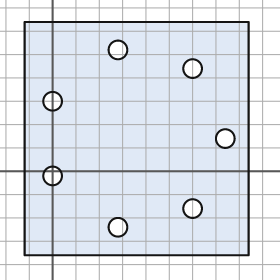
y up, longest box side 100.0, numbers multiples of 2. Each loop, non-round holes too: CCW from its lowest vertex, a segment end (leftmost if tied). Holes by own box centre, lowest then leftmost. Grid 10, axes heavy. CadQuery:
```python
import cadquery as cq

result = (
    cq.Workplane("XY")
    .moveTo(-12.0, -36.0)
    .lineTo(84.0, -36.0)
    .lineTo(84.0, 64.0)
    .lineTo(-12.0, 64.0)
    .close()
    .moveTo(28.0, -24.0)
    .circle(4.0)
    .moveTo(60.0, -16.0)
    .circle(4.0)
    .moveTo(0.0, -2.0)
    .circle(4.0)
    .moveTo(74.0, 14.0)
    .circle(4.0)
    .moveTo(0.0, 30.0)
    .circle(4.0)
    .moveTo(60.0, 44.0)
    .circle(4.0)
    .moveTo(28.0, 52.0)
    .circle(4.0)
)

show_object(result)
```